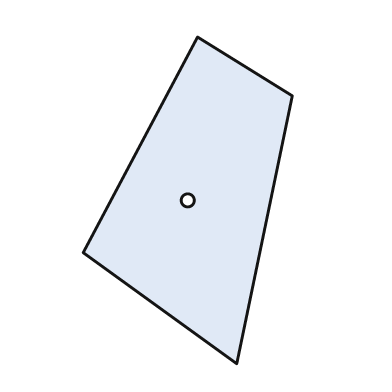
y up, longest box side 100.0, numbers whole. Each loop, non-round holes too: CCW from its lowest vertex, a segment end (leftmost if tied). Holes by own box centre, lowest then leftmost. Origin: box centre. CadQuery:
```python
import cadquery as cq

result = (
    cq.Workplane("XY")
    .moveTo(15.0, -50.0)
    .lineTo(32.0, 32.0)
    .lineTo(3.0, 50.0)
    .lineTo(-32.0, -16.0)
    .close()
    .moveTo(0.0, 0.0)
    .circle(2.0)
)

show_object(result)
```